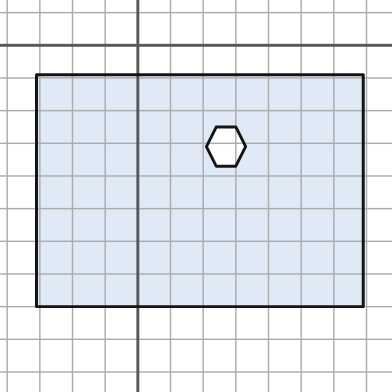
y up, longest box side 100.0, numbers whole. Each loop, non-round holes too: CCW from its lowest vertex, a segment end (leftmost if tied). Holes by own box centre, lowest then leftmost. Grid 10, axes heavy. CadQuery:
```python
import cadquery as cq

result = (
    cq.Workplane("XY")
    .moveTo(-31.0, -80.0)
    .lineTo(69.0, -80.0)
    .lineTo(69.0, -9.0)
    .lineTo(-31.0, -9.0)
    .close()
    .moveTo(24.0, -37.0)
    .lineTo(30.0, -37.0)
    .lineTo(33.0, -31.0)
    .lineTo(30.0, -25.0)
    .lineTo(24.0, -25.0)
    .lineTo(21.0, -31.0)
    .close()
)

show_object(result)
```